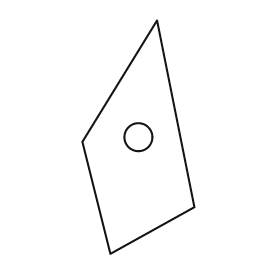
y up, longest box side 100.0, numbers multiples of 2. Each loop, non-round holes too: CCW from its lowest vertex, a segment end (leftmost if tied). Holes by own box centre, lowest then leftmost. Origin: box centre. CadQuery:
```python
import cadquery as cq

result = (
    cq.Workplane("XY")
    .moveTo(-12.0, -50.0)
    .lineTo(24.0, -30.0)
    .lineTo(8.0, 50.0)
    .lineTo(-24.0, -2.0)
    .close()
    .moveTo(0.0, 0.0)
    .circle(6.0)
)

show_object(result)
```